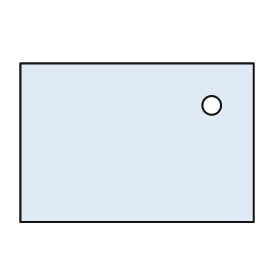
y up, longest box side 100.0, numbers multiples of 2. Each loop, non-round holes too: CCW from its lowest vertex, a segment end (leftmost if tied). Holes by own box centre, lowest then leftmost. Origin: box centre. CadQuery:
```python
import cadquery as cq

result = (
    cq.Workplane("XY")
    .moveTo(-50.0, -34.0)
    .lineTo(50.0, -34.0)
    .lineTo(50.0, 34.0)
    .lineTo(-50.0, 34.0)
    .close()
    .moveTo(32.0, 16.0)
    .circle(4.0)
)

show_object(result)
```